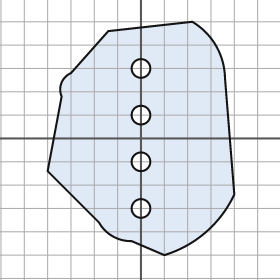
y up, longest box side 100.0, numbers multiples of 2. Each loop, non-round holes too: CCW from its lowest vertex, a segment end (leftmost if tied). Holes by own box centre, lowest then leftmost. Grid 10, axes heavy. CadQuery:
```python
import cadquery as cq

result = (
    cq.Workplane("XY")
    .moveTo(10.0, -50.0)
    .threePointArc((28.0, -40.0), (40.0, -24.0))
    .lineTo(36.0, 26.0)
    .threePointArc((32.0, 40.0), (22.0, 50.0))
    .lineTo(-14.0, 46.0)
    .lineTo(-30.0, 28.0)
    .threePointArc((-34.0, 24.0), (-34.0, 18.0))
    .lineTo(-40.0, -14.0)
    .lineTo(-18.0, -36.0)
    .threePointArc((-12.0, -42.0), (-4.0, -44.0))
    .close()
    .moveTo(0.0, -30.0)
    .circle(4.0)
    .moveTo(0.0, -10.0)
    .circle(4.0)
    .moveTo(0.0, 10.0)
    .circle(4.0)
    .moveTo(0.0, 30.0)
    .circle(4.0)
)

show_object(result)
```